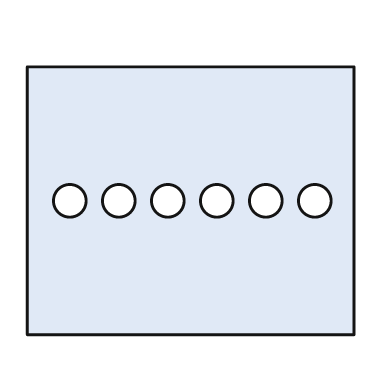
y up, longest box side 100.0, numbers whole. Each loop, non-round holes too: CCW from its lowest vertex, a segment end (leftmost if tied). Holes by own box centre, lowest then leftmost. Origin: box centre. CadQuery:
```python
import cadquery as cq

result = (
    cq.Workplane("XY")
    .moveTo(-50.0, -41.0)
    .lineTo(50.0, -41.0)
    .lineTo(50.0, 41.0)
    .lineTo(-50.0, 41.0)
    .close()
    .moveTo(-37.0, 0.0)
    .circle(5.0)
    .moveTo(-22.0, 0.0)
    .circle(5.0)
    .moveTo(-7.0, 0.0)
    .circle(5.0)
    .moveTo(8.0, 0.0)
    .circle(5.0)
    .moveTo(23.0, 0.0)
    .circle(5.0)
    .moveTo(38.0, 0.0)
    .circle(5.0)
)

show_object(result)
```